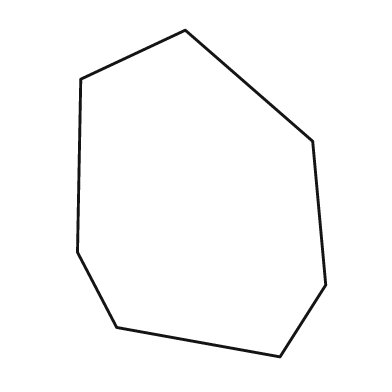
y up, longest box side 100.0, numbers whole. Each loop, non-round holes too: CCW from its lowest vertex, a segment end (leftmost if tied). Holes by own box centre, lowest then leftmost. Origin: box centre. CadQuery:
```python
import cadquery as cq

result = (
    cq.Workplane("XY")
    .moveTo(24.0, -50.0)
    .lineTo(38.0, -28.0)
    .lineTo(34.0, 16.0)
    .lineTo(-5.0, 50.0)
    .lineTo(-37.0, 35.0)
    .lineTo(-38.0, -18.0)
    .lineTo(-26.0, -41.0)
    .close()
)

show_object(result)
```